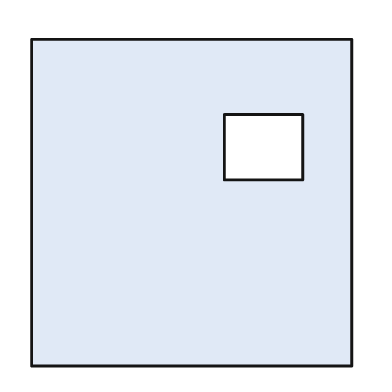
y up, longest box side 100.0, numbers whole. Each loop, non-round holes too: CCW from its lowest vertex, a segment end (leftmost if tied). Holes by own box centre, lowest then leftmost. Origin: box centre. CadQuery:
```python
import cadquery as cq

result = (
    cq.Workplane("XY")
    .moveTo(-49.0, -50.0)
    .lineTo(49.0, -50.0)
    .lineTo(49.0, 50.0)
    .lineTo(-49.0, 50.0)
    .close()
    .moveTo(10.0, 7.0)
    .lineTo(34.0, 7.0)
    .lineTo(34.0, 27.0)
    .lineTo(10.0, 27.0)
    .close()
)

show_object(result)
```